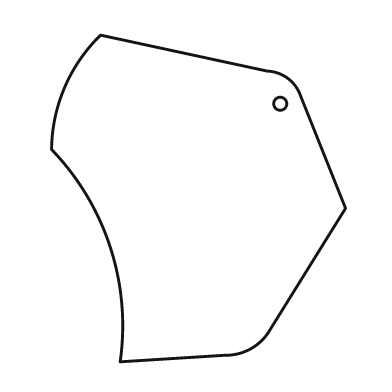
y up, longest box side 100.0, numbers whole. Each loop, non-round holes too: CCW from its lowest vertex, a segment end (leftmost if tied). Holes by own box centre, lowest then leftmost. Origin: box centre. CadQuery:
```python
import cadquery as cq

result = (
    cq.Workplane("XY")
    .moveTo(-24.0, -50.0)
    .lineTo(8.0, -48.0)
    .threePointArc((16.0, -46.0), (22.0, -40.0))
    .lineTo(45.0, -3.0)
    .lineTo(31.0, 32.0)
    .threePointArc((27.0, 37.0), (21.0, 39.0))
    .lineTo(-30.0, 50.0)
    .threePointArc((-41.0, 34.0), (-45.0, 15.0))
    .threePointArc((-27.0, -15.0), (-24.0, -50.0))
    .close()
    .moveTo(25.0, 29.0)
    .circle(2.0)
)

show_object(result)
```